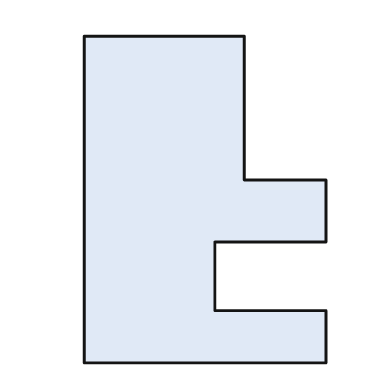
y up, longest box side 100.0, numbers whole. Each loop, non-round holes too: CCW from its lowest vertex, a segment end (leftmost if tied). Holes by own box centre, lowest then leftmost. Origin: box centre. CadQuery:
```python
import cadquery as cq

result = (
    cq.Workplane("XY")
    .moveTo(-37.0, -50.0)
    .lineTo(37.0, -50.0)
    .lineTo(37.0, -34.0)
    .lineTo(3.0, -34.0)
    .lineTo(3.0, -13.0)
    .lineTo(37.0, -13.0)
    .lineTo(37.0, 6.0)
    .lineTo(12.0, 6.0)
    .lineTo(12.0, 50.0)
    .lineTo(-37.0, 50.0)
    .close()
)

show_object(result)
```